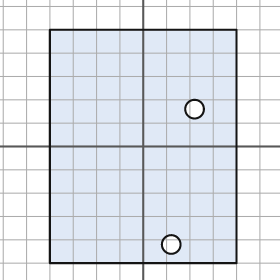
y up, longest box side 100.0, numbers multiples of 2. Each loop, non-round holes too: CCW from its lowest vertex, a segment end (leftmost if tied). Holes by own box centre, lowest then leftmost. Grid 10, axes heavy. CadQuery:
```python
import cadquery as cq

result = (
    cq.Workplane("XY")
    .moveTo(-40.0, -50.0)
    .lineTo(40.0, -50.0)
    .lineTo(40.0, 50.0)
    .lineTo(-40.0, 50.0)
    .close()
    .moveTo(12.0, -42.0)
    .circle(4.0)
    .moveTo(22.0, 16.0)
    .circle(4.0)
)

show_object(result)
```